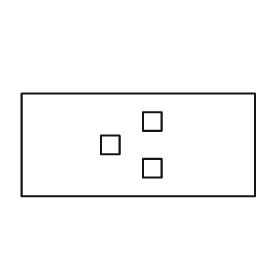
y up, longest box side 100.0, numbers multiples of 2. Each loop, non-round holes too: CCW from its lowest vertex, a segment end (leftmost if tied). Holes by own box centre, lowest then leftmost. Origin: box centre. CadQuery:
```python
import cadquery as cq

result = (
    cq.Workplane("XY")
    .moveTo(-50.0, -22.0)
    .lineTo(50.0, -22.0)
    .lineTo(50.0, 22.0)
    .lineTo(-50.0, 22.0)
    .close()
    .moveTo(2.0, -14.0)
    .lineTo(10.0, -14.0)
    .lineTo(10.0, -6.0)
    .lineTo(2.0, -6.0)
    .close()
    .moveTo(-16.0, -4.0)
    .lineTo(-8.0, -4.0)
    .lineTo(-8.0, 4.0)
    .lineTo(-16.0, 4.0)
    .close()
    .moveTo(2.0, 6.0)
    .lineTo(10.0, 6.0)
    .lineTo(10.0, 14.0)
    .lineTo(2.0, 14.0)
    .close()
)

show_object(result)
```